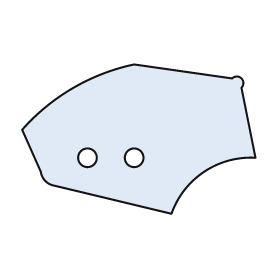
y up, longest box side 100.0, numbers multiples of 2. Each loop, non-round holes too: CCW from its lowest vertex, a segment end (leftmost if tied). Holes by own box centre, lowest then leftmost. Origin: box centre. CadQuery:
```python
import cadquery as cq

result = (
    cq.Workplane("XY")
    .moveTo(14.0, -32.0)
    .threePointArc((28.0, -14.0), (50.0, -8.0))
    .lineTo(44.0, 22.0)
    .threePointArc((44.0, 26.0), (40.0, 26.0))
    .lineTo(-2.0, 32.0)
    .threePointArc((-28.0, 22.0), (-50.0, 4.0))
    .lineTo(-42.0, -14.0)
    .threePointArc((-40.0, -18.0), (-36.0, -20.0))
    .close()
    .moveTo(-22.0, -8.0)
    .circle(4.0)
    .moveTo(-2.0, -8.0)
    .circle(4.0)
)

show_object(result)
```